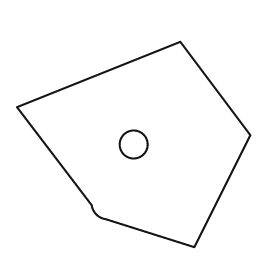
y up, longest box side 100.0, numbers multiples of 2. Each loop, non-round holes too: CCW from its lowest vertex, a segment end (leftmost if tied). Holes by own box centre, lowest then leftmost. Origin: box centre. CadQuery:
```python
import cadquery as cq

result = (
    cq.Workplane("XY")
    .moveTo(26.0, -44.0)
    .lineTo(50.0, 4.0)
    .lineTo(20.0, 44.0)
    .lineTo(-50.0, 16.0)
    .lineTo(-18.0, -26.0)
    .threePointArc((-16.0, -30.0), (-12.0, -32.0))
    .close()
    .moveTo(0.0, 0.0)
    .circle(6.0)
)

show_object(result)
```